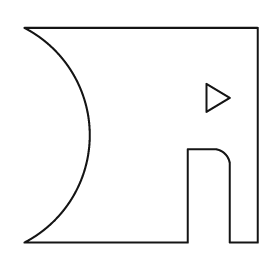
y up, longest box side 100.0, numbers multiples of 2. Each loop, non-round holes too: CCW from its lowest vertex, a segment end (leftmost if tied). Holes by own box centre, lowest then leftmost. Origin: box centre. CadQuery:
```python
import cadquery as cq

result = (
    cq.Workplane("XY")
    .moveTo(-50.0, -46.0)
    .lineTo(20.0, -46.0)
    .lineTo(20.0, -6.0)
    .lineTo(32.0, -6.0)
    .threePointArc((36.0, -8.0), (38.0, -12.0))
    .lineTo(38.0, -46.0)
    .lineTo(50.0, -46.0)
    .lineTo(50.0, 46.0)
    .lineTo(-50.0, 46.0)
    .threePointArc((-22.0, 0.0), (-50.0, -46.0))
    .close()
    .moveTo(28.0, 10.0)
    .lineTo(38.0, 16.0)
    .lineTo(28.0, 22.0)
    .close()
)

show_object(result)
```